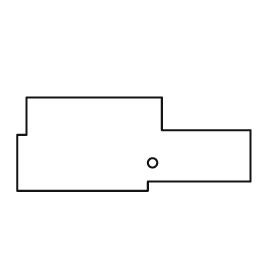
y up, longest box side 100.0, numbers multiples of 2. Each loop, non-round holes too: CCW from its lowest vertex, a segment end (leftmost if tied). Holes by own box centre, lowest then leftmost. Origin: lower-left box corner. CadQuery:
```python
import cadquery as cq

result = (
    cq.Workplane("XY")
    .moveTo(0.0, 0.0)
    .lineTo(56.0, 0.0)
    .lineTo(56.0, 4.0)
    .lineTo(100.0, 4.0)
    .lineTo(100.0, 26.0)
    .lineTo(62.0, 26.0)
    .lineTo(62.0, 40.0)
    .lineTo(4.0, 40.0)
    .lineTo(4.0, 24.0)
    .lineTo(0.0, 24.0)
    .close()
    .moveTo(58.0, 12.0)
    .circle(2.0)
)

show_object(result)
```